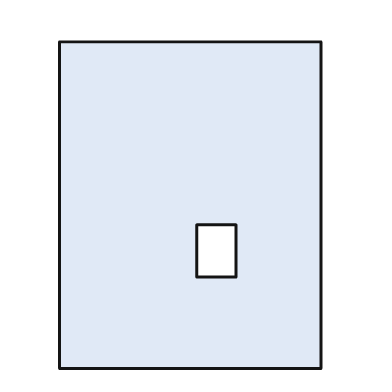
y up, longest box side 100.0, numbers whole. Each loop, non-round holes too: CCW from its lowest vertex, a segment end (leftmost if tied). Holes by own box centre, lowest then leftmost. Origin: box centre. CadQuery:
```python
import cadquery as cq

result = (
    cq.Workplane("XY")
    .moveTo(-40.0, -50.0)
    .lineTo(40.0, -50.0)
    .lineTo(40.0, 50.0)
    .lineTo(-40.0, 50.0)
    .close()
    .moveTo(2.0, -22.0)
    .lineTo(14.0, -22.0)
    .lineTo(14.0, -6.0)
    .lineTo(2.0, -6.0)
    .close()
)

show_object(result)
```